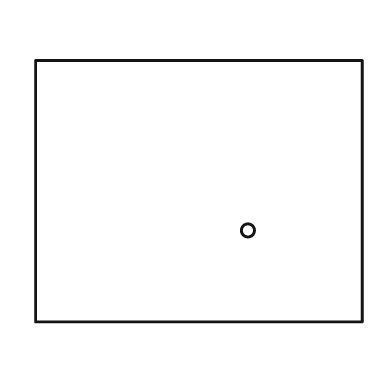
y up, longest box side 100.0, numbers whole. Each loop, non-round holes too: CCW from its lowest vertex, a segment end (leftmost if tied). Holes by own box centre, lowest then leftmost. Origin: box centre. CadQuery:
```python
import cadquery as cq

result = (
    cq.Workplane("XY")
    .moveTo(-50.0, -40.0)
    .lineTo(50.0, -40.0)
    .lineTo(50.0, 40.0)
    .lineTo(-50.0, 40.0)
    .close()
    .moveTo(15.0, -12.0)
    .circle(2.0)
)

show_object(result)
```